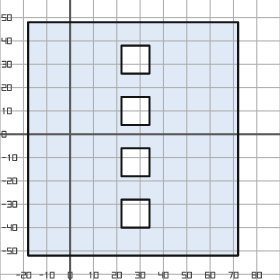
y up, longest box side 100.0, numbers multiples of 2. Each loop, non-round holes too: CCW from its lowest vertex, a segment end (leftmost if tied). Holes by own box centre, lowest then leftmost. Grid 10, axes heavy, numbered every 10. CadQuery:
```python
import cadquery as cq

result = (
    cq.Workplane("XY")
    .moveTo(-18.0, -52.0)
    .lineTo(72.0, -52.0)
    .lineTo(72.0, 48.0)
    .lineTo(-18.0, 48.0)
    .close()
    .moveTo(22.0, -40.0)
    .lineTo(34.0, -40.0)
    .lineTo(34.0, -28.0)
    .lineTo(22.0, -28.0)
    .close()
    .moveTo(22.0, -18.0)
    .lineTo(34.0, -18.0)
    .lineTo(34.0, -6.0)
    .lineTo(22.0, -6.0)
    .close()
    .moveTo(22.0, 4.0)
    .lineTo(34.0, 4.0)
    .lineTo(34.0, 16.0)
    .lineTo(22.0, 16.0)
    .close()
    .moveTo(22.0, 26.0)
    .lineTo(34.0, 26.0)
    .lineTo(34.0, 38.0)
    .lineTo(22.0, 38.0)
    .close()
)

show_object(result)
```